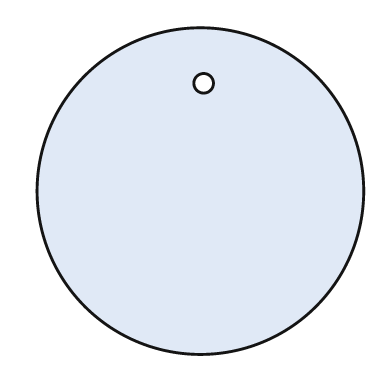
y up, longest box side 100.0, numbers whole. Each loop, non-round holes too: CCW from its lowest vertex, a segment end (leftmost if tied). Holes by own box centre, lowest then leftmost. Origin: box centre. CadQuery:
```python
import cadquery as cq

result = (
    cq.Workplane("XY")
    .moveTo(0.0, 0.0)
    .circle(50.0)
    .moveTo(1.0, 33.0)
    .circle(3.0)
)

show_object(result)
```